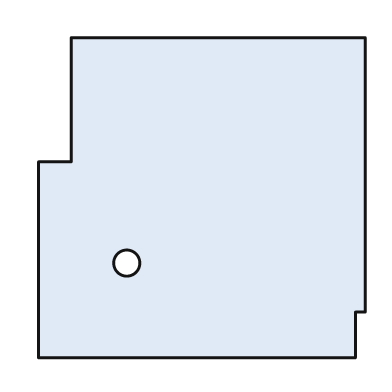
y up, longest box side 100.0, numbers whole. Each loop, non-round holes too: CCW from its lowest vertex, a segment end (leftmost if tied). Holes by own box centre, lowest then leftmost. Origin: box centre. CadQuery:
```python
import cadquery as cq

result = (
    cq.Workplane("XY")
    .moveTo(-50.0, -49.0)
    .lineTo(47.0, -49.0)
    .lineTo(47.0, -35.0)
    .lineTo(50.0, -35.0)
    .lineTo(50.0, 49.0)
    .lineTo(-40.0, 49.0)
    .lineTo(-40.0, 11.0)
    .lineTo(-50.0, 11.0)
    .close()
    .moveTo(-23.0, -20.0)
    .circle(4.0)
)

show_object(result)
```